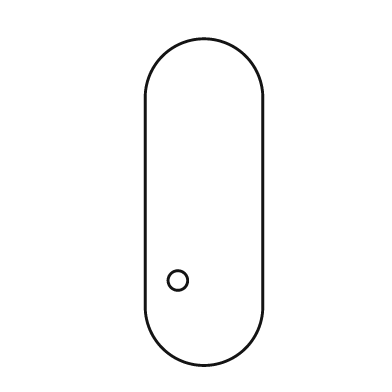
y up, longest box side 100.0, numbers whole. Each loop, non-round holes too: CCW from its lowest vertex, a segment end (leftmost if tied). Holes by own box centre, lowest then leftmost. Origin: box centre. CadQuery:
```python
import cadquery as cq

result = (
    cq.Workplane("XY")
    .moveTo(-18.0, -32.0)
    .threePointArc((0.0, -50.0), (18.0, -32.0))
    .lineTo(18.0, 32.0)
    .threePointArc((0.0, 50.0), (-18.0, 32.0))
    .close()
    .moveTo(-8.0, -24.0)
    .circle(3.0)
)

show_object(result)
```